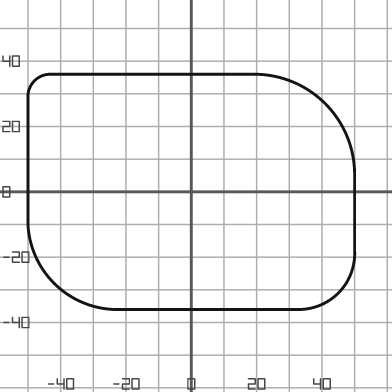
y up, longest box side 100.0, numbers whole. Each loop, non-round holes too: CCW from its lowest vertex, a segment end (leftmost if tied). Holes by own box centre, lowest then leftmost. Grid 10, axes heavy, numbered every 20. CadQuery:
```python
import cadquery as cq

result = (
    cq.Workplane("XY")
    .moveTo(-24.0, -36.0)
    .lineTo(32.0, -36.0)
    .threePointArc((45.0, -31.0), (50.0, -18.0))
    .lineTo(50.0, 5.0)
    .threePointArc((41.0, 27.0), (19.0, 36.0))
    .lineTo(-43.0, 36.0)
    .threePointArc((-48.0, 34.0), (-50.0, 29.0))
    .lineTo(-50.0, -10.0)
    .threePointArc((-42.0, -28.0), (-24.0, -36.0))
    .close()
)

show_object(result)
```